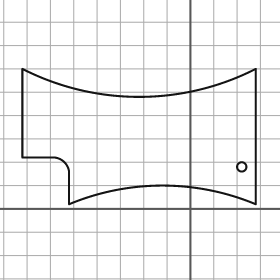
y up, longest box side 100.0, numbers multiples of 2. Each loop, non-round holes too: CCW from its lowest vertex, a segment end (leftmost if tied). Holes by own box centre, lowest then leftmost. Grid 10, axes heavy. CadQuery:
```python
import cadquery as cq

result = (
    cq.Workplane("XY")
    .moveTo(-52.0, 2.0)
    .threePointArc((-12.0, 10.0), (28.0, 2.0))
    .lineTo(28.0, 60.0)
    .threePointArc((-22.0, 48.0), (-72.0, 60.0))
    .lineTo(-72.0, 22.0)
    .lineTo(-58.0, 22.0)
    .threePointArc((-54.0, 20.0), (-52.0, 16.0))
    .close()
    .moveTo(22.0, 18.0)
    .circle(2.0)
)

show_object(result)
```